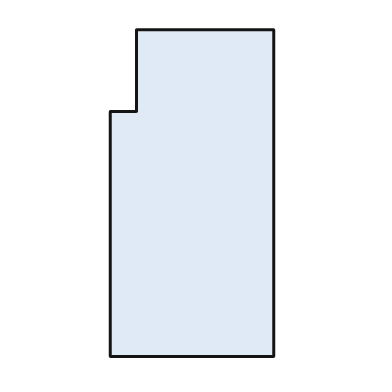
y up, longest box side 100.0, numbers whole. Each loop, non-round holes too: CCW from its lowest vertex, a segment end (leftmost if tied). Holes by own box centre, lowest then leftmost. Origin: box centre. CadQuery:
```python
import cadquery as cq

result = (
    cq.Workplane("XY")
    .moveTo(-25.0, -50.0)
    .lineTo(25.0, -50.0)
    .lineTo(25.0, 50.0)
    .lineTo(-17.0, 50.0)
    .lineTo(-17.0, 25.0)
    .lineTo(-25.0, 25.0)
    .close()
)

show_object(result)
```